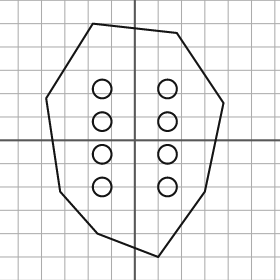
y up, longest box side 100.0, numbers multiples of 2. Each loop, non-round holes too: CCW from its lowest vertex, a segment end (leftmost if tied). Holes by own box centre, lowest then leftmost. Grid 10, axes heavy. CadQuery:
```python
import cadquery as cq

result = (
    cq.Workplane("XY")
    .moveTo(10.0, -50.0)
    .lineTo(30.0, -22.0)
    .lineTo(38.0, 16.0)
    .lineTo(18.0, 46.0)
    .lineTo(-18.0, 50.0)
    .lineTo(-38.0, 18.0)
    .lineTo(-32.0, -22.0)
    .lineTo(-16.0, -40.0)
    .close()
    .moveTo(-14.0, -20.0)
    .circle(4.0)
    .moveTo(14.0, -20.0)
    .circle(4.0)
    .moveTo(-14.0, -6.0)
    .circle(4.0)
    .moveTo(14.0, -6.0)
    .circle(4.0)
    .moveTo(-14.0, 8.0)
    .circle(4.0)
    .moveTo(14.0, 8.0)
    .circle(4.0)
    .moveTo(-14.0, 22.0)
    .circle(4.0)
    .moveTo(14.0, 22.0)
    .circle(4.0)
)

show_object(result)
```